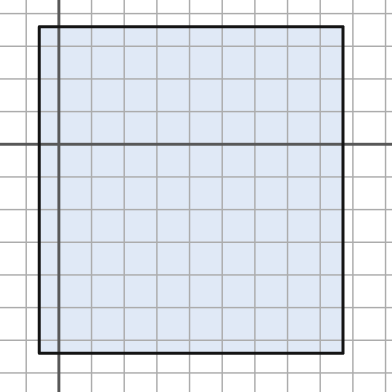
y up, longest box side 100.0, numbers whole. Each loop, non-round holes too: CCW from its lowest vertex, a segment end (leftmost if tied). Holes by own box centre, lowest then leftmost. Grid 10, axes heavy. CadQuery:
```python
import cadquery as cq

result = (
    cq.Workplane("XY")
    .moveTo(-6.0, -64.0)
    .lineTo(87.0, -64.0)
    .lineTo(87.0, 36.0)
    .lineTo(-6.0, 36.0)
    .close()
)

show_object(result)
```